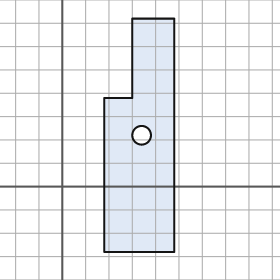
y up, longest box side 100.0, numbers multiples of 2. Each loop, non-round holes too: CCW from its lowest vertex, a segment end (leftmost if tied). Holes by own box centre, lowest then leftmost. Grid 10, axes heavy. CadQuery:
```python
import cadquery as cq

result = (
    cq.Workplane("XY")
    .moveTo(18.0, -28.0)
    .lineTo(48.0, -28.0)
    .lineTo(48.0, 72.0)
    .lineTo(30.0, 72.0)
    .lineTo(30.0, 38.0)
    .lineTo(18.0, 38.0)
    .close()
    .moveTo(34.0, 22.0)
    .circle(4.0)
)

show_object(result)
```